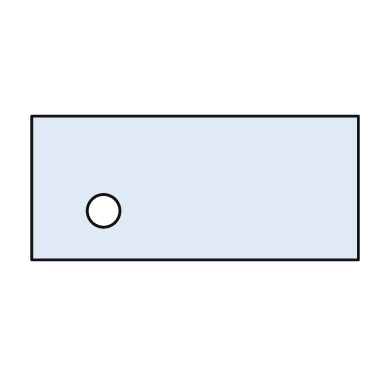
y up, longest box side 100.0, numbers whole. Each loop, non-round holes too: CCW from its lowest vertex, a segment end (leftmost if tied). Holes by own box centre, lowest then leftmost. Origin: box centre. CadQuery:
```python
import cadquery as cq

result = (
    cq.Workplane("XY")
    .moveTo(-50.0, -22.0)
    .lineTo(50.0, -22.0)
    .lineTo(50.0, 22.0)
    .lineTo(-50.0, 22.0)
    .close()
    .moveTo(-28.0, -7.0)
    .circle(5.0)
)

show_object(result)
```